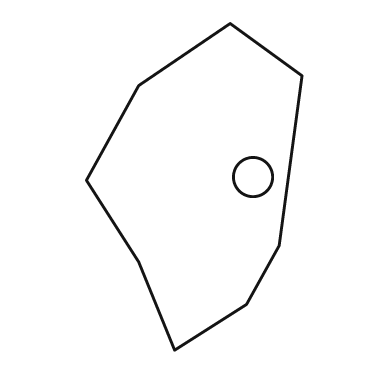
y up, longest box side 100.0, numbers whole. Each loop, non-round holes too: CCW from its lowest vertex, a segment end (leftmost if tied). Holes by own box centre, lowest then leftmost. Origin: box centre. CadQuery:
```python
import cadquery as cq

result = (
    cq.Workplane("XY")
    .moveTo(-6.0, -50.0)
    .lineTo(16.0, -36.0)
    .lineTo(26.0, -18.0)
    .lineTo(33.0, 34.0)
    .lineTo(11.0, 50.0)
    .lineTo(-17.0, 31.0)
    .lineTo(-33.0, 2.0)
    .lineTo(-17.0, -23.0)
    .close()
    .moveTo(18.0, 3.0)
    .circle(6.0)
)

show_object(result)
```